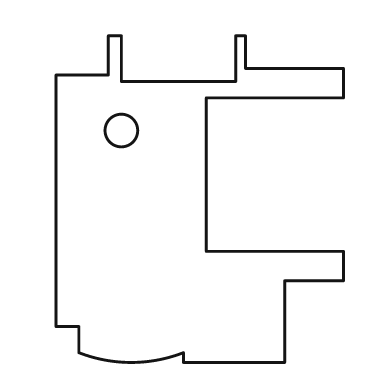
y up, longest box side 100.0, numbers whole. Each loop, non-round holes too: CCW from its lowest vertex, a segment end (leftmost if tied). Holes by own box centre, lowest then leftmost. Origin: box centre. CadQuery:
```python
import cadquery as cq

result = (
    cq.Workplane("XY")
    .moveTo(-5.0, -50.0)
    .lineTo(26.0, -50.0)
    .lineTo(26.0, -25.0)
    .lineTo(44.0, -25.0)
    .lineTo(44.0, -16.0)
    .lineTo(2.0, -16.0)
    .lineTo(2.0, 31.0)
    .lineTo(44.0, 31.0)
    .lineTo(44.0, 40.0)
    .lineTo(14.0, 40.0)
    .lineTo(14.0, 50.0)
    .lineTo(11.0, 50.0)
    .lineTo(11.0, 36.0)
    .lineTo(-24.0, 36.0)
    .lineTo(-24.0, 50.0)
    .lineTo(-28.0, 50.0)
    .lineTo(-28.0, 38.0)
    .lineTo(-44.0, 38.0)
    .lineTo(-44.0, -39.0)
    .lineTo(-37.0, -39.0)
    .lineTo(-37.0, -47.0)
    .threePointArc((-21.0, -50.0), (-5.0, -47.0))
    .close()
    .moveTo(-24.0, 21.0)
    .circle(5.0)
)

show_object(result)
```